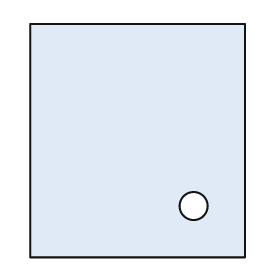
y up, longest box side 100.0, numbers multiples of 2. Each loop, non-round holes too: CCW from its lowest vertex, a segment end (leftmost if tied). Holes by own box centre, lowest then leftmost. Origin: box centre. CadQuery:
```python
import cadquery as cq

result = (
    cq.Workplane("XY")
    .moveTo(-46.0, -50.0)
    .lineTo(46.0, -50.0)
    .lineTo(46.0, 50.0)
    .lineTo(-46.0, 50.0)
    .close()
    .moveTo(24.0, -28.0)
    .circle(6.0)
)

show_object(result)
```